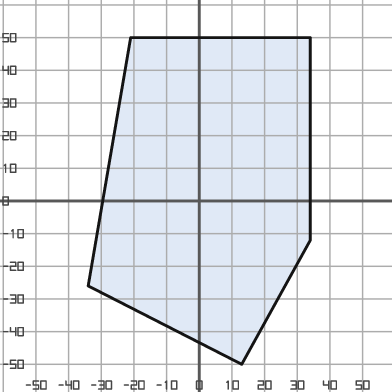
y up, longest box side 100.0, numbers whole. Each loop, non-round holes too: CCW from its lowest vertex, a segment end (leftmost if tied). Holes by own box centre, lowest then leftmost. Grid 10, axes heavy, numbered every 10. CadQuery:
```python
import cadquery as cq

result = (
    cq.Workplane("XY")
    .moveTo(13.0, -50.0)
    .lineTo(34.0, -12.0)
    .lineTo(34.0, 50.0)
    .lineTo(-21.0, 50.0)
    .lineTo(-34.0, -26.0)
    .close()
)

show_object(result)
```